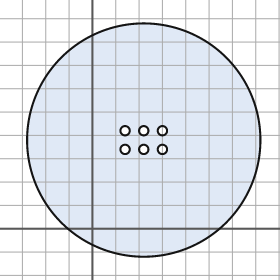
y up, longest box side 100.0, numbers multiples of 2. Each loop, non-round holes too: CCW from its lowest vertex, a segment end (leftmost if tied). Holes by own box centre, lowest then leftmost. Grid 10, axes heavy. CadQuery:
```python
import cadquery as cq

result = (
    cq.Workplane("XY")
    .moveTo(22.0, 38.0)
    .circle(50.0)
    .moveTo(14.0, 34.0)
    .circle(2.0)
    .moveTo(22.0, 34.0)
    .circle(2.0)
    .moveTo(30.0, 34.0)
    .circle(2.0)
    .moveTo(14.0, 42.0)
    .circle(2.0)
    .moveTo(22.0, 42.0)
    .circle(2.0)
    .moveTo(30.0, 42.0)
    .circle(2.0)
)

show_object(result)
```